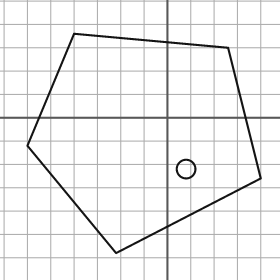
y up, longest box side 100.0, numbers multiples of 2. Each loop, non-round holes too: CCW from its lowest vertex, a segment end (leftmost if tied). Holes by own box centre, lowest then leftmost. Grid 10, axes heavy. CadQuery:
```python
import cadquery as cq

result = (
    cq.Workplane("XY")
    .moveTo(-22.0, -58.0)
    .lineTo(40.0, -26.0)
    .lineTo(26.0, 30.0)
    .lineTo(-40.0, 36.0)
    .lineTo(-60.0, -12.0)
    .close()
    .moveTo(8.0, -22.0)
    .circle(4.0)
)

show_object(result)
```